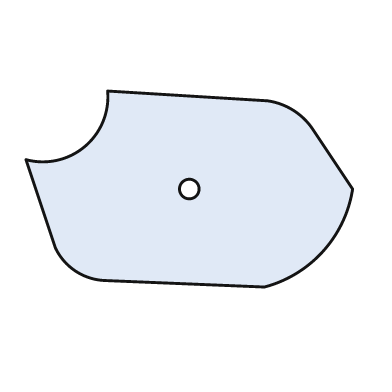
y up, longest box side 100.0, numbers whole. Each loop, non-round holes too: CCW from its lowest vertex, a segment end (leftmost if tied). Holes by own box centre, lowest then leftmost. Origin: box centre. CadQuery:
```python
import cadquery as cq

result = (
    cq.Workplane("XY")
    .moveTo(23.0, -30.0)
    .threePointArc((41.0, -19.0), (50.0, 0.0))
    .lineTo(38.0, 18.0)
    .threePointArc((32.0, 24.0), (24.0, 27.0))
    .lineTo(-25.0, 30.0)
    .threePointArc((-32.0, 13.0), (-50.0, 9.0))
    .lineTo(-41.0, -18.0)
    .threePointArc((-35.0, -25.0), (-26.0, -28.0))
    .close()
    .moveTo(0.0, 0.0)
    .circle(3.0)
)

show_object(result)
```